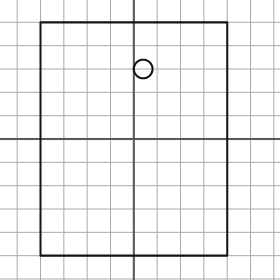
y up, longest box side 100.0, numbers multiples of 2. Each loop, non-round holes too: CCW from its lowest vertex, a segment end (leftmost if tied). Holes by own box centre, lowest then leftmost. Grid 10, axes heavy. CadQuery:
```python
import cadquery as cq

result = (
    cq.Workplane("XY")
    .moveTo(-40.0, -50.0)
    .lineTo(40.0, -50.0)
    .lineTo(40.0, 50.0)
    .lineTo(-40.0, 50.0)
    .close()
    .moveTo(4.0, 30.0)
    .circle(4.0)
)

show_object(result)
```